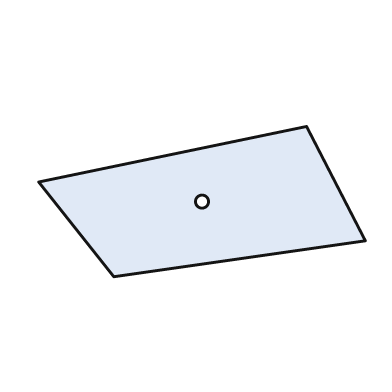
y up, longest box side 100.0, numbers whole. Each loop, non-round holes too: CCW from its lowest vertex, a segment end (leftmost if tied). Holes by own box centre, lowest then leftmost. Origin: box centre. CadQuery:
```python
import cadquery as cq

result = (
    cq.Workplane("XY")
    .moveTo(-27.0, -23.0)
    .lineTo(50.0, -12.0)
    .lineTo(32.0, 23.0)
    .lineTo(-50.0, 6.0)
    .close()
    .moveTo(0.0, 0.0)
    .circle(2.0)
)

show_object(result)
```